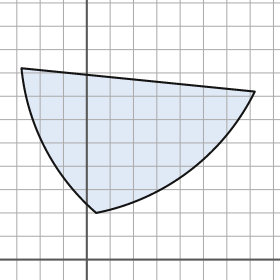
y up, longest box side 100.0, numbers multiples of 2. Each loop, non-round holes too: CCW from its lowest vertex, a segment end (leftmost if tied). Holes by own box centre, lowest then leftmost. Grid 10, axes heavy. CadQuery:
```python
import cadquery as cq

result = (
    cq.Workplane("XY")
    .moveTo(4.0, 20.0)
    .threePointArc((44.0, 38.0), (72.0, 72.0))
    .lineTo(-28.0, 82.0)
    .threePointArc((-18.0, 48.0), (4.0, 20.0))
    .close()
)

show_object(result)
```